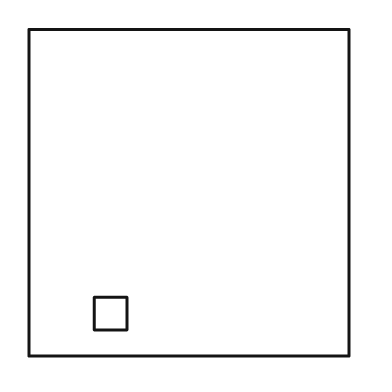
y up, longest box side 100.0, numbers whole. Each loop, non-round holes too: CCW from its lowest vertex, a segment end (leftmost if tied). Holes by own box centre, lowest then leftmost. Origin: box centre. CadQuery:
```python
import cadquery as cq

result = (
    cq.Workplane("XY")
    .moveTo(-49.0, -50.0)
    .lineTo(49.0, -50.0)
    .lineTo(49.0, 50.0)
    .lineTo(-49.0, 50.0)
    .close()
    .moveTo(-29.0, -42.0)
    .lineTo(-19.0, -42.0)
    .lineTo(-19.0, -32.0)
    .lineTo(-29.0, -32.0)
    .close()
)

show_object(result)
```